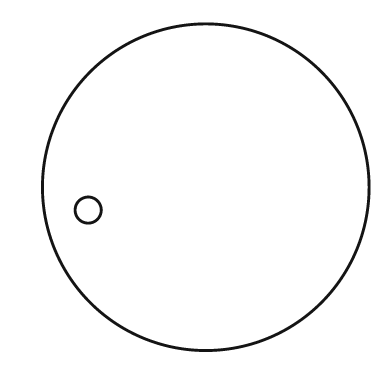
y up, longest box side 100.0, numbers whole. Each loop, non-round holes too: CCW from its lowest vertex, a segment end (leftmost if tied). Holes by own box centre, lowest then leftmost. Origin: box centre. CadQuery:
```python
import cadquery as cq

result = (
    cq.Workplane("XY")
    .moveTo(0.0, 0.0)
    .circle(50.0)
    .moveTo(-36.0, -7.0)
    .circle(4.0)
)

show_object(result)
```